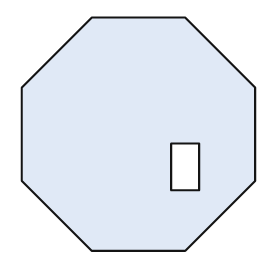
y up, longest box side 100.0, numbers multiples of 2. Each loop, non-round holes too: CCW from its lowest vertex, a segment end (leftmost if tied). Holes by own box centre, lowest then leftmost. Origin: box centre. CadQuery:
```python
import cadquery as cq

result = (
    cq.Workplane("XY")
    .moveTo(-20.0, -50.0)
    .lineTo(20.0, -50.0)
    .lineTo(50.0, -20.0)
    .lineTo(50.0, 20.0)
    .lineTo(20.0, 50.0)
    .lineTo(-20.0, 50.0)
    .lineTo(-50.0, 20.0)
    .lineTo(-50.0, -20.0)
    .close()
    .moveTo(14.0, -24.0)
    .lineTo(26.0, -24.0)
    .lineTo(26.0, -4.0)
    .lineTo(14.0, -4.0)
    .close()
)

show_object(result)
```